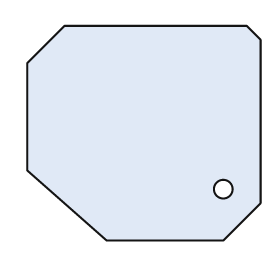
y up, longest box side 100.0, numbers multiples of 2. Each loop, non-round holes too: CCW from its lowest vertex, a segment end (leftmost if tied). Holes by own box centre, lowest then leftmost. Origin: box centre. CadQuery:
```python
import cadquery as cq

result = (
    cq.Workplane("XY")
    .moveTo(-16.0, -46.0)
    .lineTo(34.0, -46.0)
    .lineTo(50.0, -30.0)
    .lineTo(50.0, 40.0)
    .lineTo(44.0, 46.0)
    .lineTo(-34.0, 46.0)
    .lineTo(-50.0, 30.0)
    .lineTo(-50.0, -16.0)
    .close()
    .moveTo(34.0, -24.0)
    .circle(4.0)
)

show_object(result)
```